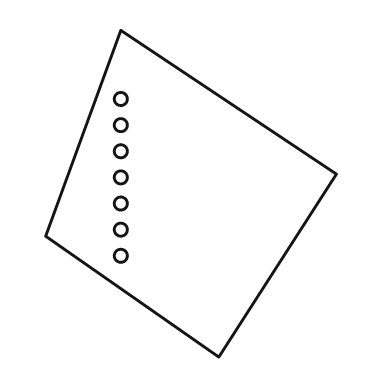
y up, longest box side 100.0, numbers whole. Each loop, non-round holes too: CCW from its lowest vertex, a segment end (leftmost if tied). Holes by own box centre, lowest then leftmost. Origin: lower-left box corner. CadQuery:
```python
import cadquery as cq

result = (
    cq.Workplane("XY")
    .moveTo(53.0, 0.0)
    .lineTo(89.0, 56.0)
    .lineTo(23.0, 100.0)
    .lineTo(0.0, 37.0)
    .close()
    .moveTo(23.0, 31.0)
    .circle(2.0)
    .moveTo(23.0, 39.0)
    .circle(2.0)
    .moveTo(23.0, 47.0)
    .circle(2.0)
    .moveTo(23.0, 55.0)
    .circle(2.0)
    .moveTo(23.0, 63.0)
    .circle(2.0)
    .moveTo(23.0, 71.0)
    .circle(2.0)
    .moveTo(23.0, 79.0)
    .circle(2.0)
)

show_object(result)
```